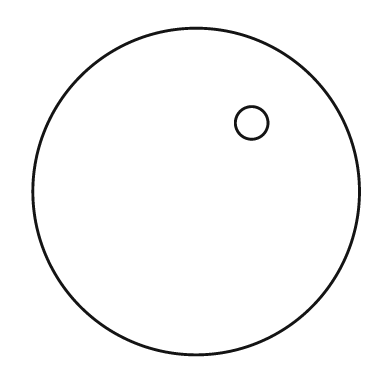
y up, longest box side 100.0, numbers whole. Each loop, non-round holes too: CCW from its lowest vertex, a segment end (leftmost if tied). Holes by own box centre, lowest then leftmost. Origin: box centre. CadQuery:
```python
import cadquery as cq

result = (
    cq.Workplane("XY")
    .moveTo(0.0, 0.0)
    .circle(50.0)
    .moveTo(17.0, 21.0)
    .circle(5.0)
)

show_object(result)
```